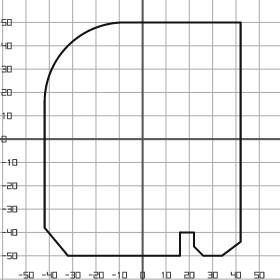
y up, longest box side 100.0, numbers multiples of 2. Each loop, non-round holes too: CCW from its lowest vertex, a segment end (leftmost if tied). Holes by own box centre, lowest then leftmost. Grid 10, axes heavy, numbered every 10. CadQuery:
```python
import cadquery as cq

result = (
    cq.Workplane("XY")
    .moveTo(-32.0, -50.0)
    .lineTo(16.0, -50.0)
    .lineTo(16.0, -40.0)
    .lineTo(22.0, -40.0)
    .lineTo(22.0, -46.0)
    .lineTo(26.0, -50.0)
    .lineTo(34.0, -50.0)
    .lineTo(42.0, -44.0)
    .lineTo(42.0, 50.0)
    .lineTo(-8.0, 50.0)
    .threePointArc((-32.0, 40.0), (-42.0, 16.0))
    .lineTo(-42.0, -38.0)
    .close()
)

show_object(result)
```